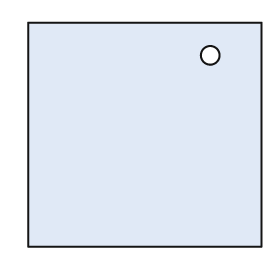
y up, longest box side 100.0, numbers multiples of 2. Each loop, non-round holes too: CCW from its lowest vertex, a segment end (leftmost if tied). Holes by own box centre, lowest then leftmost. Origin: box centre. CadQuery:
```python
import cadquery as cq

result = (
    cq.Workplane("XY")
    .moveTo(-50.0, -48.0)
    .lineTo(50.0, -48.0)
    .lineTo(50.0, 48.0)
    .lineTo(-50.0, 48.0)
    .close()
    .moveTo(28.0, 34.0)
    .circle(4.0)
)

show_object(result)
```